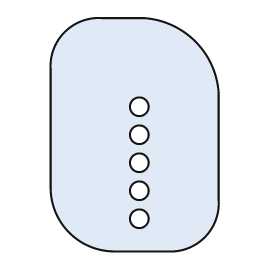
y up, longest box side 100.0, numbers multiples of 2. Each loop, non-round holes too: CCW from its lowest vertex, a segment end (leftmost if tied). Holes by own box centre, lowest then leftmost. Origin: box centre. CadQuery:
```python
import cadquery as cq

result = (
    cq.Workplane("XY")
    .moveTo(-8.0, -50.0)
    .lineTo(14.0, -50.0)
    .threePointArc((30.0, -44.0), (36.0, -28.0))
    .lineTo(36.0, 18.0)
    .threePointArc((26.0, 40.0), (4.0, 50.0))
    .lineTo(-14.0, 50.0)
    .threePointArc((-30.0, 44.0), (-36.0, 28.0))
    .lineTo(-36.0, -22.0)
    .threePointArc((-28.0, -42.0), (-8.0, -50.0))
    .close()
    .moveTo(2.0, -36.0)
    .circle(4.0)
    .moveTo(2.0, -24.0)
    .circle(4.0)
    .moveTo(2.0, -12.0)
    .circle(4.0)
    .moveTo(2.0, 0.0)
    .circle(4.0)
    .moveTo(2.0, 12.0)
    .circle(4.0)
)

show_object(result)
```